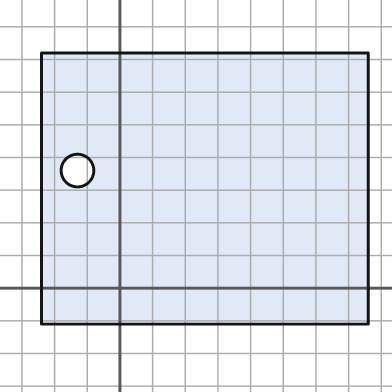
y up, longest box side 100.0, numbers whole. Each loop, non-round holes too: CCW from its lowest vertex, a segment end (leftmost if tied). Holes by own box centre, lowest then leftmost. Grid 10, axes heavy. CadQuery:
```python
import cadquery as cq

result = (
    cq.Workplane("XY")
    .moveTo(-24.0, -11.0)
    .lineTo(76.0, -11.0)
    .lineTo(76.0, 72.0)
    .lineTo(-24.0, 72.0)
    .close()
    .moveTo(-13.0, 36.0)
    .circle(5.0)
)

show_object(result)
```